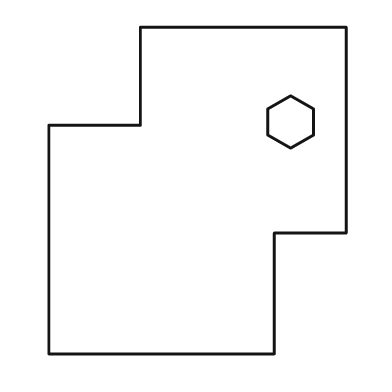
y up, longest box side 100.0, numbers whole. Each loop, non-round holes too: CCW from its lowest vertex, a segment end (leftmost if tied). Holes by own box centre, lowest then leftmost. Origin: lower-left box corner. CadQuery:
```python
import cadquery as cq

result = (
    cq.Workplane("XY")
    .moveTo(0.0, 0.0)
    .lineTo(69.0, 0.0)
    .lineTo(69.0, 37.0)
    .lineTo(91.0, 37.0)
    .lineTo(91.0, 100.0)
    .lineTo(28.0, 100.0)
    .lineTo(28.0, 70.0)
    .lineTo(0.0, 70.0)
    .close()
    .moveTo(74.0, 63.0)
    .lineTo(81.0, 67.0)
    .lineTo(81.0, 75.0)
    .lineTo(74.0, 79.0)
    .lineTo(67.0, 75.0)
    .lineTo(67.0, 67.0)
    .close()
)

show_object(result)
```